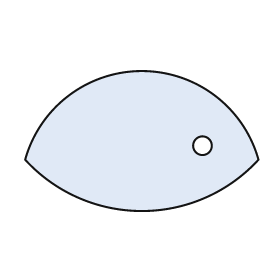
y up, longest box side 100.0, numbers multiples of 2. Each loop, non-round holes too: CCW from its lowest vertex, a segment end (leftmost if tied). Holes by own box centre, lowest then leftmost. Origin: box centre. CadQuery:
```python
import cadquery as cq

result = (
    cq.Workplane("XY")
    .moveTo(-50.0, -8.0)
    .threePointArc((0.0, -30.0), (50.0, -8.0))
    .threePointArc((0.0, 30.0), (-50.0, -8.0))
    .close()
    .moveTo(26.0, -2.0)
    .circle(4.0)
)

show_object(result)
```